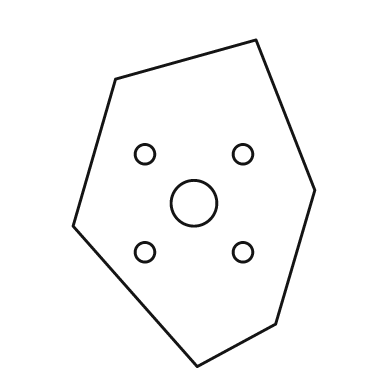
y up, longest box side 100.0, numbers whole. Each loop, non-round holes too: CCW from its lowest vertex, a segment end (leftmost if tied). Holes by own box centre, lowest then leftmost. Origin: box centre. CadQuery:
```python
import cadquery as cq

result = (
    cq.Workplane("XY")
    .moveTo(1.0, -50.0)
    .lineTo(25.0, -37.0)
    .lineTo(37.0, 4.0)
    .lineTo(19.0, 50.0)
    .lineTo(-24.0, 38.0)
    .lineTo(-37.0, -7.0)
    .close()
    .moveTo(-15.0, -15.0)
    .circle(3.0)
    .moveTo(15.0, -15.0)
    .circle(3.0)
    .moveTo(0.0, 0.0)
    .circle(7.0)
    .moveTo(-15.0, 15.0)
    .circle(3.0)
    .moveTo(15.0, 15.0)
    .circle(3.0)
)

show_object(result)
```